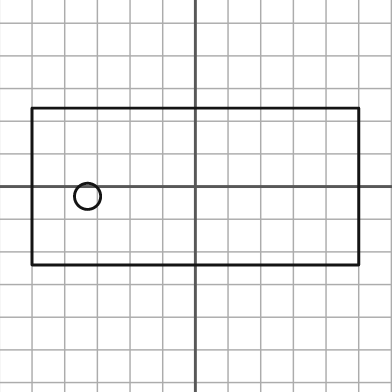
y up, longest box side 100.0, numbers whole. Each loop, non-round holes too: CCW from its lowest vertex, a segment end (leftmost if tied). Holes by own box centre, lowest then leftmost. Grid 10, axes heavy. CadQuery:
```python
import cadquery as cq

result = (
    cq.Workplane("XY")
    .moveTo(-50.0, -24.0)
    .lineTo(50.0, -24.0)
    .lineTo(50.0, 24.0)
    .lineTo(-50.0, 24.0)
    .close()
    .moveTo(-33.0, -3.0)
    .circle(4.0)
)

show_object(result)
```